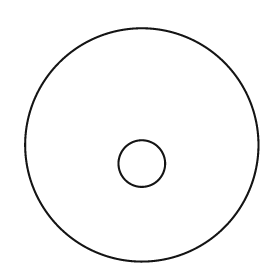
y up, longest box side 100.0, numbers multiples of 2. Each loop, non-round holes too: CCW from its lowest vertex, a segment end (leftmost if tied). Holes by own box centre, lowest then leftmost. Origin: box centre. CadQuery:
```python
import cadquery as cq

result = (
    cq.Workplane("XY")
    .moveTo(0.0, 0.0)
    .circle(50.0)
    .moveTo(0.0, -8.0)
    .circle(10.0)
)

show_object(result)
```